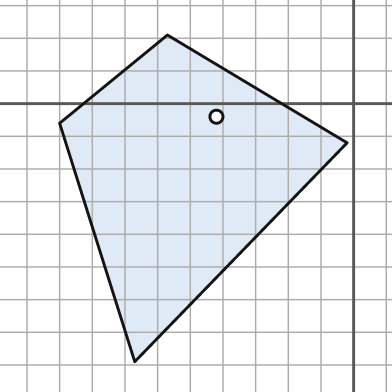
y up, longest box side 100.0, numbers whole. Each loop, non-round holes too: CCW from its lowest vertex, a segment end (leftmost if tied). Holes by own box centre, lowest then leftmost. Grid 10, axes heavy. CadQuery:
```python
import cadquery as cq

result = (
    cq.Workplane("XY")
    .moveTo(-67.0, -79.0)
    .lineTo(-2.0, -12.0)
    .lineTo(-57.0, 21.0)
    .lineTo(-90.0, -6.0)
    .close()
    .moveTo(-42.0, -4.0)
    .circle(2.0)
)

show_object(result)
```